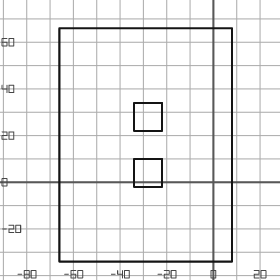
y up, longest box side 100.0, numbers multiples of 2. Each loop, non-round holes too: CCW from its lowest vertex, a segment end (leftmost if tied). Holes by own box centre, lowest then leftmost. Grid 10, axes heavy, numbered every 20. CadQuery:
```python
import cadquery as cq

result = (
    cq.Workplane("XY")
    .moveTo(-66.0, -34.0)
    .lineTo(8.0, -34.0)
    .lineTo(8.0, 66.0)
    .lineTo(-66.0, 66.0)
    .close()
    .moveTo(-34.0, -2.0)
    .lineTo(-22.0, -2.0)
    .lineTo(-22.0, 10.0)
    .lineTo(-34.0, 10.0)
    .close()
    .moveTo(-34.0, 22.0)
    .lineTo(-22.0, 22.0)
    .lineTo(-22.0, 34.0)
    .lineTo(-34.0, 34.0)
    .close()
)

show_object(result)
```